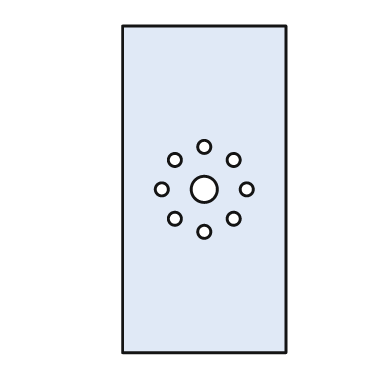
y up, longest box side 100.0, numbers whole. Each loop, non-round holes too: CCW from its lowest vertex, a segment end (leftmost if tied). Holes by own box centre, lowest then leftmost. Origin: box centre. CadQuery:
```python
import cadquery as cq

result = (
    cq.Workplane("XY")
    .moveTo(-25.0, -50.0)
    .lineTo(25.0, -50.0)
    .lineTo(25.0, 50.0)
    .lineTo(-25.0, 50.0)
    .close()
    .moveTo(0.0, -13.0)
    .circle(2.0)
    .moveTo(-9.0, -9.0)
    .circle(2.0)
    .moveTo(9.0, -9.0)
    .circle(2.0)
    .moveTo(-13.0, 0.0)
    .circle(2.0)
    .moveTo(0.0, 0.0)
    .circle(4.0)
    .moveTo(13.0, 0.0)
    .circle(2.0)
    .moveTo(-9.0, 9.0)
    .circle(2.0)
    .moveTo(9.0, 9.0)
    .circle(2.0)
    .moveTo(0.0, 13.0)
    .circle(2.0)
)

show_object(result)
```